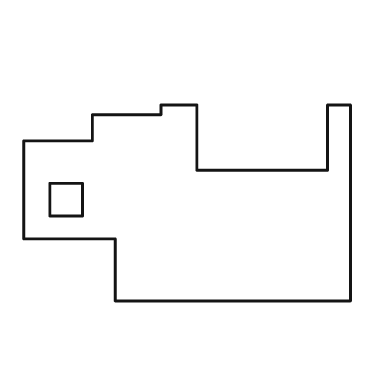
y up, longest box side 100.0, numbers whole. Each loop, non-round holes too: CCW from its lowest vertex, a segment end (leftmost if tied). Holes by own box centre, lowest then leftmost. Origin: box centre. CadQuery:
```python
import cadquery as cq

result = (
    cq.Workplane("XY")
    .moveTo(-22.0, -30.0)
    .lineTo(50.0, -30.0)
    .lineTo(50.0, 30.0)
    .lineTo(43.0, 30.0)
    .lineTo(43.0, 10.0)
    .lineTo(3.0, 10.0)
    .lineTo(3.0, 30.0)
    .lineTo(-8.0, 30.0)
    .lineTo(-8.0, 27.0)
    .lineTo(-29.0, 27.0)
    .lineTo(-29.0, 19.0)
    .lineTo(-50.0, 19.0)
    .lineTo(-50.0, -11.0)
    .lineTo(-22.0, -11.0)
    .close()
    .moveTo(-42.0, -4.0)
    .lineTo(-32.0, -4.0)
    .lineTo(-32.0, 6.0)
    .lineTo(-42.0, 6.0)
    .close()
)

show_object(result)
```